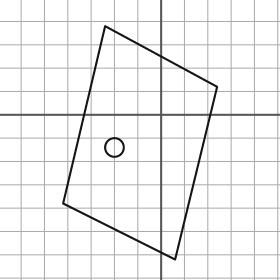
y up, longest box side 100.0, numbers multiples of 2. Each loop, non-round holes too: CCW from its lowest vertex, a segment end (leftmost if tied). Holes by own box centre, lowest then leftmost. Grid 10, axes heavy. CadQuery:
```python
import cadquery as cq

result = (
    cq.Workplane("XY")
    .moveTo(6.0, -62.0)
    .lineTo(24.0, 12.0)
    .lineTo(-24.0, 38.0)
    .lineTo(-42.0, -38.0)
    .close()
    .moveTo(-20.0, -14.0)
    .circle(4.0)
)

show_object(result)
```